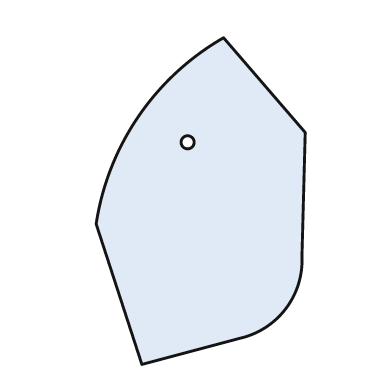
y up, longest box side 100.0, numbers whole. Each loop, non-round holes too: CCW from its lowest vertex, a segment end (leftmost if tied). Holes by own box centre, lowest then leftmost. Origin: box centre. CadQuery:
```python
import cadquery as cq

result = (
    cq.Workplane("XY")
    .moveTo(-18.0, -50.0)
    .lineTo(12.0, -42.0)
    .threePointArc((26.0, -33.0), (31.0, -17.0))
    .lineTo(32.0, 21.0)
    .lineTo(7.0, 50.0)
    .threePointArc((-19.0, 26.0), (-32.0, -7.0))
    .close()
    .moveTo(-4.0, 18.0)
    .circle(2.0)
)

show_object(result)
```